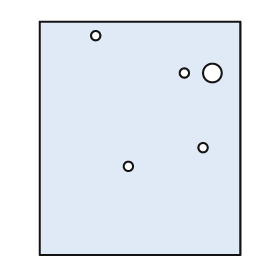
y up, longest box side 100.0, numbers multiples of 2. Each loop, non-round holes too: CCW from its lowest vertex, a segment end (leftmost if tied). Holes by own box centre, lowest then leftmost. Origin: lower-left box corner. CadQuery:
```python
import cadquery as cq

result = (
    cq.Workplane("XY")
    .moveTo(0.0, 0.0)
    .lineTo(86.0, 0.0)
    .lineTo(86.0, 100.0)
    .lineTo(0.0, 100.0)
    .close()
    .moveTo(38.0, 38.0)
    .circle(2.0)
    .moveTo(70.0, 46.0)
    .circle(2.0)
    .moveTo(62.0, 78.0)
    .circle(2.0)
    .moveTo(74.0, 78.0)
    .circle(4.0)
    .moveTo(24.0, 94.0)
    .circle(2.0)
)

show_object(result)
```